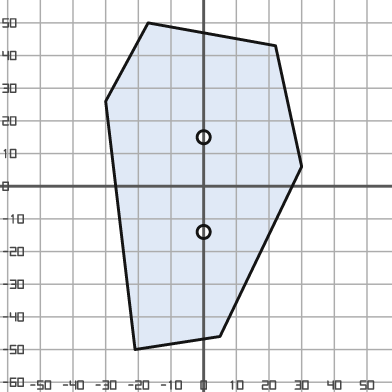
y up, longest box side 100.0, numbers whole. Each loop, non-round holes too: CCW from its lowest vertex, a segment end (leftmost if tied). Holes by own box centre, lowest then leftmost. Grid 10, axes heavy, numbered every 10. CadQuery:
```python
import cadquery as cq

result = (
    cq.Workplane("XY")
    .moveTo(-21.0, -50.0)
    .lineTo(5.0, -46.0)
    .lineTo(30.0, 6.0)
    .lineTo(22.0, 43.0)
    .lineTo(-17.0, 50.0)
    .lineTo(-30.0, 26.0)
    .close()
    .moveTo(0.0, -14.0)
    .circle(2.0)
    .moveTo(0.0, 15.0)
    .circle(2.0)
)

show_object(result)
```